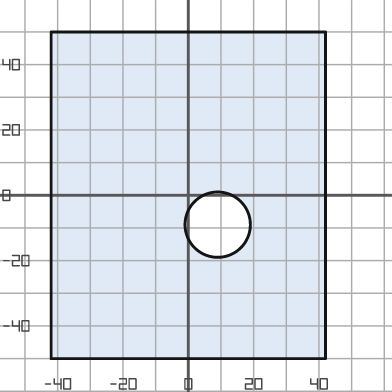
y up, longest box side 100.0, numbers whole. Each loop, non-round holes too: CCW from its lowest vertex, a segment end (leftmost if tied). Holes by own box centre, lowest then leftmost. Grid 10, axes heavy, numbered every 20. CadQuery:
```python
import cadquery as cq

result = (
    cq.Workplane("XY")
    .moveTo(-42.0, -50.0)
    .lineTo(42.0, -50.0)
    .lineTo(42.0, 50.0)
    .lineTo(-42.0, 50.0)
    .close()
    .moveTo(9.0, -9.0)
    .circle(10.0)
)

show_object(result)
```